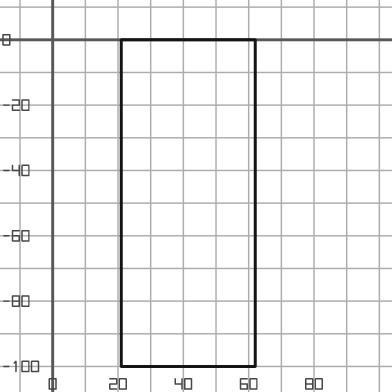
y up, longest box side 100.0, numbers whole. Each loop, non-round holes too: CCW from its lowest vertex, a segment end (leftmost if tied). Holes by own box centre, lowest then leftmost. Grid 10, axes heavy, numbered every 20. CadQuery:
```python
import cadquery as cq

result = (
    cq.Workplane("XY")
    .moveTo(21.0, -100.0)
    .lineTo(62.0, -100.0)
    .lineTo(62.0, 0.0)
    .lineTo(21.0, 0.0)
    .close()
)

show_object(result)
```